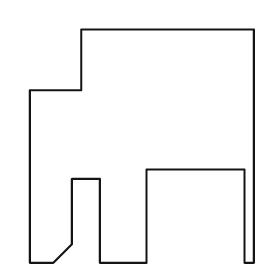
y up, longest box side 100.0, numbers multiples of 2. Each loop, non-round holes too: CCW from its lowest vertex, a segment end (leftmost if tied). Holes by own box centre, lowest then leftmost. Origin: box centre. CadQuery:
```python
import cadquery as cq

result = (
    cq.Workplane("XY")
    .moveTo(-48.0, -50.0)
    .lineTo(-38.0, -50.0)
    .lineTo(-30.0, -42.0)
    .lineTo(-30.0, -14.0)
    .lineTo(-18.0, -14.0)
    .lineTo(-18.0, -50.0)
    .lineTo(2.0, -50.0)
    .lineTo(2.0, -10.0)
    .lineTo(44.0, -10.0)
    .lineTo(44.0, -50.0)
    .lineTo(48.0, -50.0)
    .lineTo(48.0, 50.0)
    .lineTo(-26.0, 50.0)
    .lineTo(-26.0, 24.0)
    .lineTo(-48.0, 24.0)
    .close()
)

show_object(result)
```